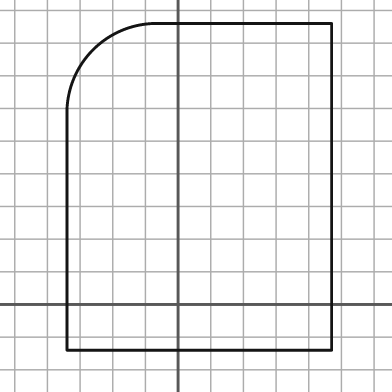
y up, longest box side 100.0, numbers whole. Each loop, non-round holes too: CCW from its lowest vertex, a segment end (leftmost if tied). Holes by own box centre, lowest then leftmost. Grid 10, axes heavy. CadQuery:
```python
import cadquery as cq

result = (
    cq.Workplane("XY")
    .moveTo(-34.0, -14.0)
    .lineTo(47.0, -14.0)
    .lineTo(47.0, 86.0)
    .lineTo(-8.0, 86.0)
    .threePointArc((-26.0, 78.0), (-34.0, 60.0))
    .close()
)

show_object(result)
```